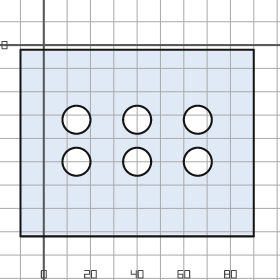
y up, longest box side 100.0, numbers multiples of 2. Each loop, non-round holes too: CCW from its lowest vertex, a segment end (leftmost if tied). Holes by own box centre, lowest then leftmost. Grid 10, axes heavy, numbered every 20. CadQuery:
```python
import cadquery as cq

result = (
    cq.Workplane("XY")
    .moveTo(-10.0, -82.0)
    .lineTo(90.0, -82.0)
    .lineTo(90.0, -2.0)
    .lineTo(-10.0, -2.0)
    .close()
    .moveTo(14.0, -50.0)
    .circle(6.0)
    .moveTo(40.0, -50.0)
    .circle(6.0)
    .moveTo(66.0, -50.0)
    .circle(6.0)
    .moveTo(14.0, -32.0)
    .circle(6.0)
    .moveTo(40.0, -32.0)
    .circle(6.0)
    .moveTo(66.0, -32.0)
    .circle(6.0)
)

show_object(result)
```